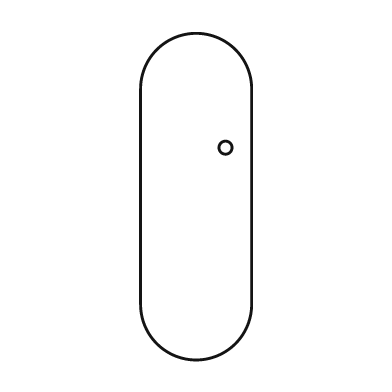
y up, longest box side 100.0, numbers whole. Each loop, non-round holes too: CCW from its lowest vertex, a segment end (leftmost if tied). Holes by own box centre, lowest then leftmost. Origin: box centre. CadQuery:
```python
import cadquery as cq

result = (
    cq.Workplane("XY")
    .moveTo(-17.0, -33.0)
    .threePointArc((0.0, -50.0), (17.0, -33.0))
    .lineTo(17.0, 33.0)
    .threePointArc((0.0, 50.0), (-17.0, 33.0))
    .close()
    .moveTo(9.0, 15.0)
    .circle(2.0)
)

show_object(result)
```